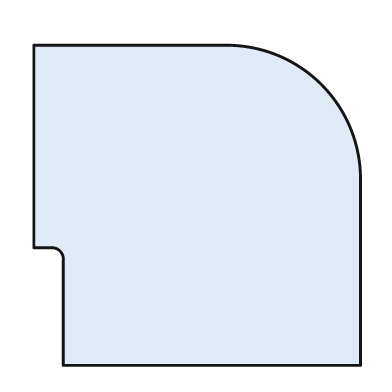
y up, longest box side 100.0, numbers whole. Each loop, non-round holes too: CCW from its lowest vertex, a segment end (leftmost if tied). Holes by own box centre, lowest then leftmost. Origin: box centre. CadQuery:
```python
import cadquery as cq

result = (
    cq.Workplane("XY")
    .moveTo(-41.0, -49.0)
    .lineTo(50.0, -49.0)
    .lineTo(50.0, 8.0)
    .threePointArc((38.0, 37.0), (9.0, 49.0))
    .lineTo(-50.0, 49.0)
    .lineTo(-50.0, -13.0)
    .lineTo(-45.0, -13.0)
    .threePointArc((-42.0, -14.0), (-41.0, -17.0))
    .close()
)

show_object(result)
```